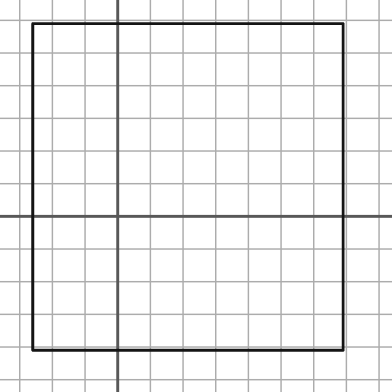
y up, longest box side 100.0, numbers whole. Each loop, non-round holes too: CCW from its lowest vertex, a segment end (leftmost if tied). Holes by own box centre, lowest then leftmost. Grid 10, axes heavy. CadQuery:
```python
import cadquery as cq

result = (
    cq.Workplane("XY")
    .moveTo(-26.0, -41.0)
    .lineTo(69.0, -41.0)
    .lineTo(69.0, 59.0)
    .lineTo(-26.0, 59.0)
    .close()
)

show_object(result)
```